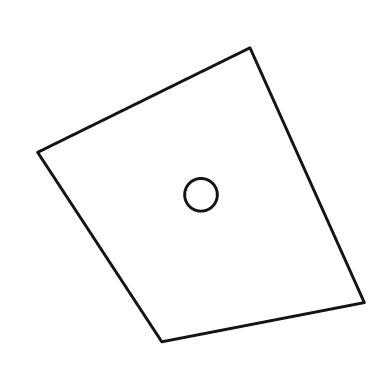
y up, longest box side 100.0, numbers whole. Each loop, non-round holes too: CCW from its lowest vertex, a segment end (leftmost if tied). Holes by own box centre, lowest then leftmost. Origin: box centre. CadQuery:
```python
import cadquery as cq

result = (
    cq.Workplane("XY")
    .moveTo(-12.0, -45.0)
    .lineTo(50.0, -33.0)
    .lineTo(15.0, 45.0)
    .lineTo(-50.0, 13.0)
    .close()
    .moveTo(0.0, 0.0)
    .circle(5.0)
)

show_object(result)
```